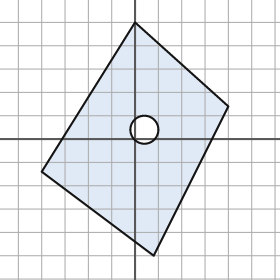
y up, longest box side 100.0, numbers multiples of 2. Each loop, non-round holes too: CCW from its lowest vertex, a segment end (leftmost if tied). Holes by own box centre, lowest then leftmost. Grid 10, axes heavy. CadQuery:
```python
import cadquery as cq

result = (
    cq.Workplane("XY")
    .moveTo(8.0, -50.0)
    .lineTo(40.0, 14.0)
    .lineTo(0.0, 50.0)
    .lineTo(-40.0, -14.0)
    .close()
    .moveTo(4.0, 4.0)
    .circle(6.0)
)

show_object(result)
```